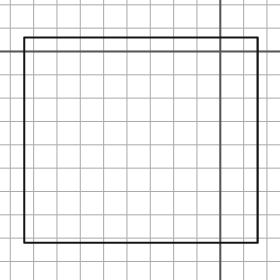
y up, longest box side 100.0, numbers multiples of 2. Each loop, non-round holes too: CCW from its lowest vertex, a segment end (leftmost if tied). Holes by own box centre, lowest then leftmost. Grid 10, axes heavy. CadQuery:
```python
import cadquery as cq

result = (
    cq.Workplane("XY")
    .moveTo(-84.0, -82.0)
    .lineTo(16.0, -82.0)
    .lineTo(16.0, 6.0)
    .lineTo(-84.0, 6.0)
    .close()
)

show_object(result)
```